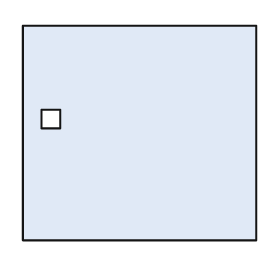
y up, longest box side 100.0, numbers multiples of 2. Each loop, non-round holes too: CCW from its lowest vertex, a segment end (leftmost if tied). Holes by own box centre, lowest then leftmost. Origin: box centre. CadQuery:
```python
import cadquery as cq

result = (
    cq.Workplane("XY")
    .moveTo(-50.0, -46.0)
    .lineTo(50.0, -46.0)
    .lineTo(50.0, 46.0)
    .lineTo(-50.0, 46.0)
    .close()
    .moveTo(-42.0, 2.0)
    .lineTo(-34.0, 2.0)
    .lineTo(-34.0, 10.0)
    .lineTo(-42.0, 10.0)
    .close()
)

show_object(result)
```